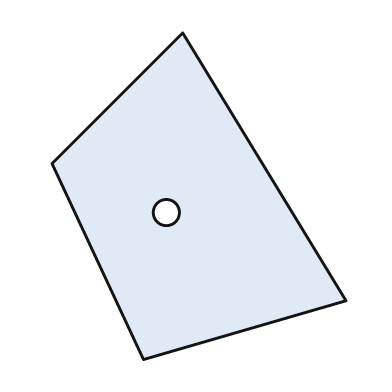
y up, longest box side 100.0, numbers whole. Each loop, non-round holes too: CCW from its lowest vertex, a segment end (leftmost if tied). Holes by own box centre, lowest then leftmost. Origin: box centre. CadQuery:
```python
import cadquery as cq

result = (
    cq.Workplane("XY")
    .moveTo(-17.0, -50.0)
    .lineTo(45.0, -32.0)
    .lineTo(-5.0, 50.0)
    .lineTo(-45.0, 10.0)
    .close()
    .moveTo(-10.0, -5.0)
    .circle(4.0)
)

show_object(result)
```